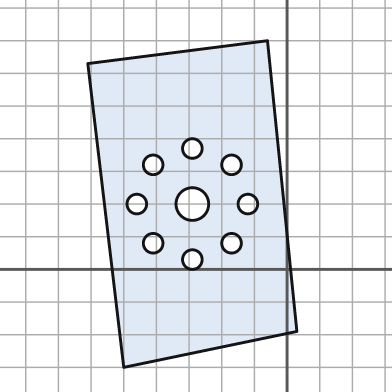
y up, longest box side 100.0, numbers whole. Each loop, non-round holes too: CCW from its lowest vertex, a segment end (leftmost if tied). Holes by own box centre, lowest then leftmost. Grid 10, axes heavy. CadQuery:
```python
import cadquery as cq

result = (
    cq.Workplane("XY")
    .moveTo(-50.0, -30.0)
    .lineTo(3.0, -19.0)
    .lineTo(-6.0, 70.0)
    .lineTo(-61.0, 63.0)
    .close()
    .moveTo(-29.0, 3.0)
    .circle(3.0)
    .moveTo(-41.0, 8.0)
    .circle(3.0)
    .moveTo(-17.0, 8.0)
    .circle(3.0)
    .moveTo(-46.0, 20.0)
    .circle(3.0)
    .moveTo(-29.0, 20.0)
    .circle(5.0)
    .moveTo(-12.0, 20.0)
    .circle(3.0)
    .moveTo(-41.0, 32.0)
    .circle(3.0)
    .moveTo(-17.0, 32.0)
    .circle(3.0)
    .moveTo(-29.0, 37.0)
    .circle(3.0)
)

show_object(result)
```